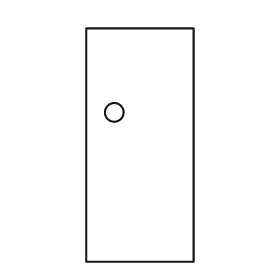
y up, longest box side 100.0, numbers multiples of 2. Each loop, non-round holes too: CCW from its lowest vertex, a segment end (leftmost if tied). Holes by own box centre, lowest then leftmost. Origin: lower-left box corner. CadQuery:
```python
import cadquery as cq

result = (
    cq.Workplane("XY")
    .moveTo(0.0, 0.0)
    .lineTo(46.0, 0.0)
    .lineTo(46.0, 100.0)
    .lineTo(0.0, 100.0)
    .close()
    .moveTo(12.0, 64.0)
    .circle(4.0)
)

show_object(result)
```